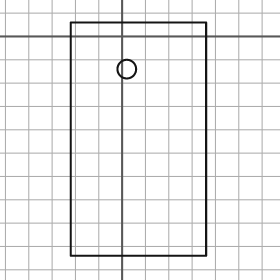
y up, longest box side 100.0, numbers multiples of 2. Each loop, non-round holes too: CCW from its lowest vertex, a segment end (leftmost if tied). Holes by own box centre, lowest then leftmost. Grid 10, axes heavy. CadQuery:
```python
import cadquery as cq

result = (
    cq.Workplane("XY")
    .moveTo(-22.0, -94.0)
    .lineTo(36.0, -94.0)
    .lineTo(36.0, 6.0)
    .lineTo(-22.0, 6.0)
    .close()
    .moveTo(2.0, -14.0)
    .circle(4.0)
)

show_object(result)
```